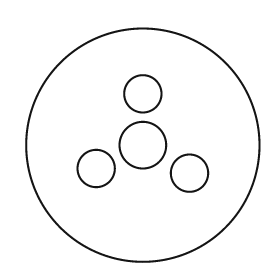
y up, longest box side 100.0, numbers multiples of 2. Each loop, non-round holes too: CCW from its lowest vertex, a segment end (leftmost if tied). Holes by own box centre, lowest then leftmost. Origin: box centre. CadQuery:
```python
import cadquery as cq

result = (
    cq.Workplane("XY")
    .moveTo(0.0, 0.0)
    .circle(50.0)
    .moveTo(20.0, -12.0)
    .circle(8.0)
    .moveTo(-20.0, -10.0)
    .circle(8.0)
    .moveTo(0.0, 0.0)
    .circle(10.0)
    .moveTo(0.0, 22.0)
    .circle(8.0)
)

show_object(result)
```